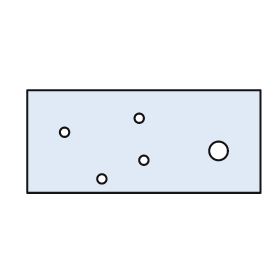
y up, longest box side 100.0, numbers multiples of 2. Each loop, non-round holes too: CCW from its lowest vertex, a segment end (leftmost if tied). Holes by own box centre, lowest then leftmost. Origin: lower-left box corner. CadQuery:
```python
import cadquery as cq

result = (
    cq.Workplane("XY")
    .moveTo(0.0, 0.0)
    .lineTo(100.0, 0.0)
    .lineTo(100.0, 44.0)
    .lineTo(0.0, 44.0)
    .close()
    .moveTo(32.0, 6.0)
    .circle(2.0)
    .moveTo(50.0, 14.0)
    .circle(2.0)
    .moveTo(82.0, 18.0)
    .circle(4.0)
    .moveTo(16.0, 26.0)
    .circle(2.0)
    .moveTo(48.0, 32.0)
    .circle(2.0)
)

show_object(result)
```